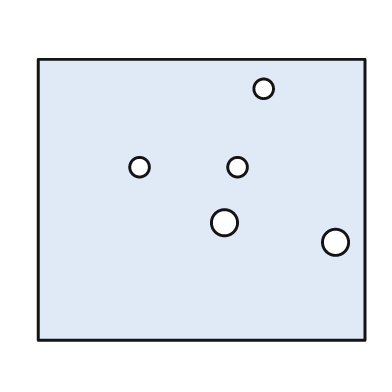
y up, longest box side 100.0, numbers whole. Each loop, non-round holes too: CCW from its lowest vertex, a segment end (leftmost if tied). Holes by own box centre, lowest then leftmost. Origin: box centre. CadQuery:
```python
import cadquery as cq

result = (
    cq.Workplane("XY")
    .moveTo(-50.0, -43.0)
    .lineTo(50.0, -43.0)
    .lineTo(50.0, 43.0)
    .lineTo(-50.0, 43.0)
    .close()
    .moveTo(41.0, -13.0)
    .circle(4.0)
    .moveTo(7.0, -7.0)
    .circle(4.0)
    .moveTo(-19.0, 10.0)
    .circle(3.0)
    .moveTo(11.0, 10.0)
    .circle(3.0)
    .moveTo(19.0, 34.0)
    .circle(3.0)
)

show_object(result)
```